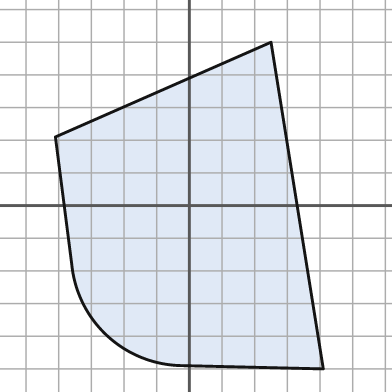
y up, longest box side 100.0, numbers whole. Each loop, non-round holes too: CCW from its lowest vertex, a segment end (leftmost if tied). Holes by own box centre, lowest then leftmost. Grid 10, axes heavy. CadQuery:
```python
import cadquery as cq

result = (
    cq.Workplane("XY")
    .moveTo(41.0, -50.0)
    .lineTo(25.0, 50.0)
    .lineTo(-41.0, 21.0)
    .lineTo(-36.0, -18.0)
    .threePointArc((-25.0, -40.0), (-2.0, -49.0))
    .close()
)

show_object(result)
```